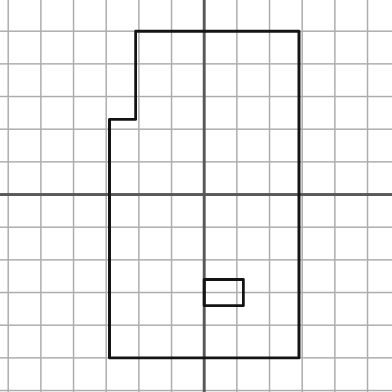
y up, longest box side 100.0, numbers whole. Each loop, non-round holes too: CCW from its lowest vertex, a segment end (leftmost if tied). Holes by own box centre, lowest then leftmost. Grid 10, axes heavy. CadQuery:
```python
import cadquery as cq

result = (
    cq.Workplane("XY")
    .moveTo(-29.0, -50.0)
    .lineTo(29.0, -50.0)
    .lineTo(29.0, 50.0)
    .lineTo(-21.0, 50.0)
    .lineTo(-21.0, 23.0)
    .lineTo(-29.0, 23.0)
    .close()
    .moveTo(0.0, -34.0)
    .lineTo(12.0, -34.0)
    .lineTo(12.0, -26.0)
    .lineTo(0.0, -26.0)
    .close()
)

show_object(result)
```